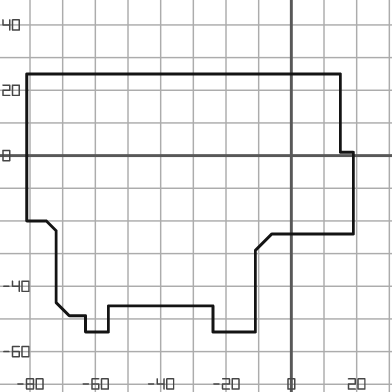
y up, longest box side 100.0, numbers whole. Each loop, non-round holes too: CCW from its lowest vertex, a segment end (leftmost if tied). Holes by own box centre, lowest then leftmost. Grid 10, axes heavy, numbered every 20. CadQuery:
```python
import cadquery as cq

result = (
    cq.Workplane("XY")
    .moveTo(-63.0, -54.0)
    .lineTo(-56.0, -54.0)
    .lineTo(-56.0, -46.0)
    .lineTo(-24.0, -46.0)
    .lineTo(-24.0, -54.0)
    .lineTo(-11.0, -54.0)
    .lineTo(-11.0, -29.0)
    .lineTo(-6.0, -24.0)
    .lineTo(19.0, -24.0)
    .lineTo(19.0, 1.0)
    .lineTo(15.0, 1.0)
    .lineTo(15.0, 25.0)
    .lineTo(-81.0, 25.0)
    .lineTo(-81.0, -20.0)
    .lineTo(-75.0, -20.0)
    .lineTo(-72.0, -23.0)
    .lineTo(-72.0, -45.0)
    .lineTo(-68.0, -49.0)
    .lineTo(-63.0, -49.0)
    .close()
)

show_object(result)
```